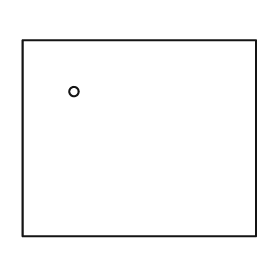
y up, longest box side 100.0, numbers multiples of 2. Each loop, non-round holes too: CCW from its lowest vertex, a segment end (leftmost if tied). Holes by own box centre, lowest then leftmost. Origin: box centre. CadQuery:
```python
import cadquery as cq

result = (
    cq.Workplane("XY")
    .moveTo(-50.0, -42.0)
    .lineTo(50.0, -42.0)
    .lineTo(50.0, 42.0)
    .lineTo(-50.0, 42.0)
    .close()
    .moveTo(-28.0, 20.0)
    .circle(2.0)
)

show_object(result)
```